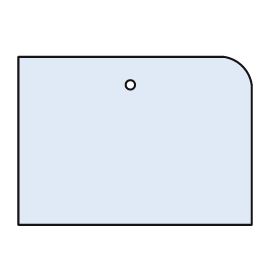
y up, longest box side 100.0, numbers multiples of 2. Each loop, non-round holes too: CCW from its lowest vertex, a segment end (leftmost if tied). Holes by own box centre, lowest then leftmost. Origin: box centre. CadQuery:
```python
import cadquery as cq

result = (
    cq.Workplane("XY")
    .moveTo(-50.0, -36.0)
    .lineTo(50.0, -36.0)
    .lineTo(50.0, 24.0)
    .threePointArc((46.0, 32.0), (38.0, 36.0))
    .lineTo(-50.0, 36.0)
    .close()
    .moveTo(-2.0, 24.0)
    .circle(2.0)
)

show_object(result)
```